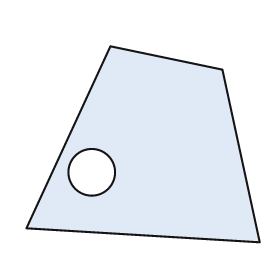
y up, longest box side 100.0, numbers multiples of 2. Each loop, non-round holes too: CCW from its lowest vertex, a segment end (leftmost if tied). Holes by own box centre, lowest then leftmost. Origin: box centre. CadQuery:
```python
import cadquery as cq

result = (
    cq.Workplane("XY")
    .moveTo(50.0, -42.0)
    .lineTo(34.0, 32.0)
    .lineTo(-14.0, 42.0)
    .lineTo(-50.0, -36.0)
    .close()
    .moveTo(-22.0, -12.0)
    .circle(10.0)
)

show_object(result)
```